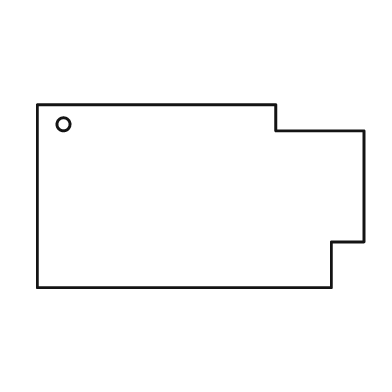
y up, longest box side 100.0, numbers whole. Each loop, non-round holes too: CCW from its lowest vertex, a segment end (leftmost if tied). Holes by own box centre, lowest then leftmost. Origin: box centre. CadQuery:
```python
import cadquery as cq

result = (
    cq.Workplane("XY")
    .moveTo(-50.0, -28.0)
    .lineTo(40.0, -28.0)
    .lineTo(40.0, -14.0)
    .lineTo(50.0, -14.0)
    .lineTo(50.0, 20.0)
    .lineTo(23.0, 20.0)
    .lineTo(23.0, 28.0)
    .lineTo(-50.0, 28.0)
    .close()
    .moveTo(-42.0, 22.0)
    .circle(2.0)
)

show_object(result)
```